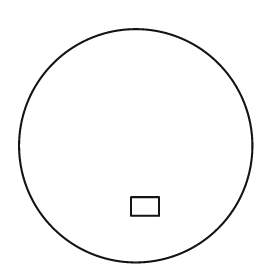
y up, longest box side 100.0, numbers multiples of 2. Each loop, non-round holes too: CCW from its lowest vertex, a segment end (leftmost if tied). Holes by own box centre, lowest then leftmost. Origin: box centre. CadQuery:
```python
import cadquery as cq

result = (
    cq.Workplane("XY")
    .moveTo(0.0, 0.0)
    .circle(50.0)
    .moveTo(-2.0, -30.0)
    .lineTo(10.0, -30.0)
    .lineTo(10.0, -22.0)
    .lineTo(-2.0, -22.0)
    .close()
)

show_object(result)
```